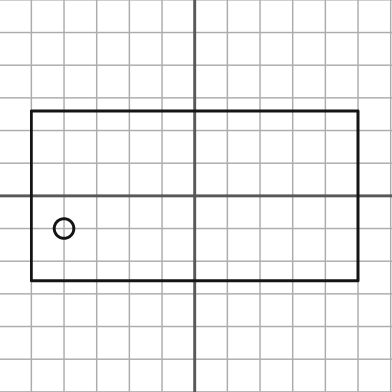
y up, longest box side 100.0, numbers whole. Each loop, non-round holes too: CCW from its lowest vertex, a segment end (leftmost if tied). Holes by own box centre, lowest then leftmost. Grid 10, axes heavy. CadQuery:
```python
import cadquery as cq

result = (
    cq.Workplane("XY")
    .moveTo(-50.0, -26.0)
    .lineTo(50.0, -26.0)
    .lineTo(50.0, 26.0)
    .lineTo(-50.0, 26.0)
    .close()
    .moveTo(-40.0, -10.0)
    .circle(3.0)
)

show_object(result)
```